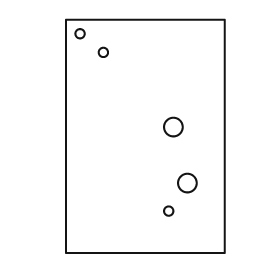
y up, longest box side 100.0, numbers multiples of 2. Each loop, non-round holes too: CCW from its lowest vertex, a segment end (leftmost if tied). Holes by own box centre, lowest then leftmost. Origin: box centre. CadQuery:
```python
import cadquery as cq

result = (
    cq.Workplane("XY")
    .moveTo(-34.0, -50.0)
    .lineTo(34.0, -50.0)
    .lineTo(34.0, 50.0)
    .lineTo(-34.0, 50.0)
    .close()
    .moveTo(10.0, -32.0)
    .circle(2.0)
    .moveTo(18.0, -20.0)
    .circle(4.0)
    .moveTo(12.0, 4.0)
    .circle(4.0)
    .moveTo(-18.0, 36.0)
    .circle(2.0)
    .moveTo(-28.0, 44.0)
    .circle(2.0)
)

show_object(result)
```